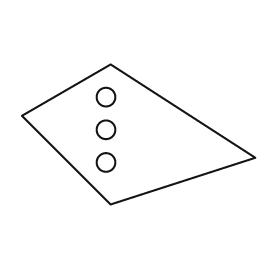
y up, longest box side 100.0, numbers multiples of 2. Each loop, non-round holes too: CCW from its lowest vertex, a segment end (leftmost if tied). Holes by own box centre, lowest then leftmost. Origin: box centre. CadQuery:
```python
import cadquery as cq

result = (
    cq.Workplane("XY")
    .moveTo(-12.0, -30.0)
    .lineTo(50.0, -10.0)
    .lineTo(-12.0, 30.0)
    .lineTo(-50.0, 8.0)
    .close()
    .moveTo(-14.0, -12.0)
    .circle(4.0)
    .moveTo(-14.0, 2.0)
    .circle(4.0)
    .moveTo(-14.0, 16.0)
    .circle(4.0)
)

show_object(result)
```